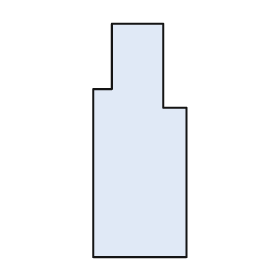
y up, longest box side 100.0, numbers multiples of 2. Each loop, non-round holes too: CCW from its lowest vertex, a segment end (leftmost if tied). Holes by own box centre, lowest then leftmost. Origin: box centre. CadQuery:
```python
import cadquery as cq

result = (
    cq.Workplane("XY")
    .moveTo(-20.0, -50.0)
    .lineTo(20.0, -50.0)
    .lineTo(20.0, 14.0)
    .lineTo(10.0, 14.0)
    .lineTo(10.0, 50.0)
    .lineTo(-12.0, 50.0)
    .lineTo(-12.0, 22.0)
    .lineTo(-20.0, 22.0)
    .close()
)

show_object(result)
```